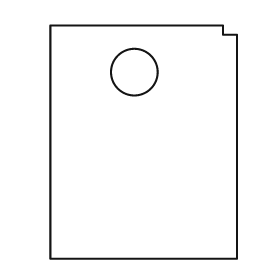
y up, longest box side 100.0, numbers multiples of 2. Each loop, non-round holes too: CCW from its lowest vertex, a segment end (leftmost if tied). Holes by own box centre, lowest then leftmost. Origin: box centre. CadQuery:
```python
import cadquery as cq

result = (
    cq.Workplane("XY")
    .moveTo(-40.0, -50.0)
    .lineTo(40.0, -50.0)
    .lineTo(40.0, 46.0)
    .lineTo(34.0, 46.0)
    .lineTo(34.0, 50.0)
    .lineTo(-40.0, 50.0)
    .close()
    .moveTo(-4.0, 30.0)
    .circle(10.0)
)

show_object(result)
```